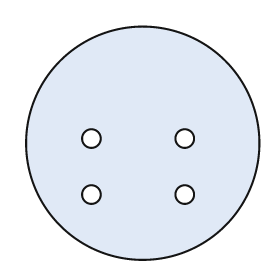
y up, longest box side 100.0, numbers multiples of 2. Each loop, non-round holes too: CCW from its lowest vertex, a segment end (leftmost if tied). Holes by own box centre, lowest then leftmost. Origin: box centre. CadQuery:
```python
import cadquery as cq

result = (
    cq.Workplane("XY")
    .moveTo(0.0, 0.0)
    .circle(50.0)
    .moveTo(-22.0, -22.0)
    .circle(4.0)
    .moveTo(18.0, -22.0)
    .circle(4.0)
    .moveTo(-22.0, 2.0)
    .circle(4.0)
    .moveTo(18.0, 2.0)
    .circle(4.0)
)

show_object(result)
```